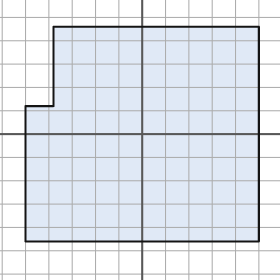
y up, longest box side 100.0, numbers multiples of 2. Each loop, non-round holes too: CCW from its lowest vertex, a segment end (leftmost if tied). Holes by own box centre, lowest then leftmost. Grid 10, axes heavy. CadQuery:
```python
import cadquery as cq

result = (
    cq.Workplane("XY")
    .moveTo(-50.0, -46.0)
    .lineTo(50.0, -46.0)
    .lineTo(50.0, 46.0)
    .lineTo(-38.0, 46.0)
    .lineTo(-38.0, 12.0)
    .lineTo(-50.0, 12.0)
    .close()
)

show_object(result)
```